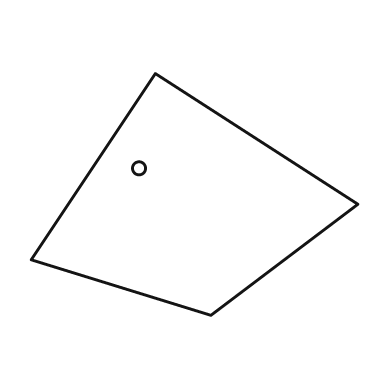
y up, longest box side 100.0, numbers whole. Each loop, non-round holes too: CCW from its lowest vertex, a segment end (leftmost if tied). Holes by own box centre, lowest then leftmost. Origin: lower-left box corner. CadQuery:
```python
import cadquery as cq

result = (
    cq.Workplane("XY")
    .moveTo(55.0, 0.0)
    .lineTo(100.0, 34.0)
    .lineTo(38.0, 74.0)
    .lineTo(0.0, 17.0)
    .close()
    .moveTo(33.0, 45.0)
    .circle(2.0)
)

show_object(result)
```